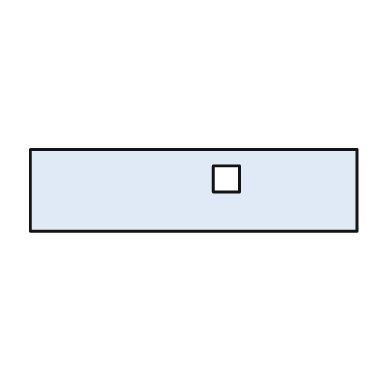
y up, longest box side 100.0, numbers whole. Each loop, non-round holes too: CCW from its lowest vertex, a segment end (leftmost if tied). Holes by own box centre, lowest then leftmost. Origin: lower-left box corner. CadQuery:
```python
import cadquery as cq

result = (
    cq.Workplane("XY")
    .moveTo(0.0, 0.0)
    .lineTo(100.0, 0.0)
    .lineTo(100.0, 25.0)
    .lineTo(0.0, 25.0)
    .close()
    .moveTo(56.0, 12.0)
    .lineTo(64.0, 12.0)
    .lineTo(64.0, 20.0)
    .lineTo(56.0, 20.0)
    .close()
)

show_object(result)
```